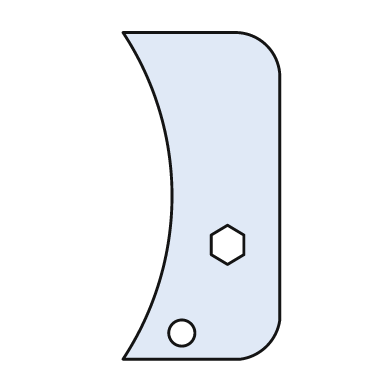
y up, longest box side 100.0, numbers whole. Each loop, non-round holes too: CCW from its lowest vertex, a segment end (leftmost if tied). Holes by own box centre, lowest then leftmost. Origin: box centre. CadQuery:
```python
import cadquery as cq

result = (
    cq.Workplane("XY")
    .moveTo(-24.0, -50.0)
    .lineTo(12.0, -50.0)
    .threePointArc((20.0, -46.0), (24.0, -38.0))
    .lineTo(24.0, 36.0)
    .threePointArc((20.0, 46.0), (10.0, 50.0))
    .lineTo(-24.0, 50.0)
    .threePointArc((-9.0, 0.0), (-24.0, -50.0))
    .close()
    .moveTo(-6.0, -42.0)
    .circle(4.0)
    .moveTo(8.0, -21.0)
    .lineTo(13.0, -18.0)
    .lineTo(13.0, -12.0)
    .lineTo(8.0, -9.0)
    .lineTo(3.0, -12.0)
    .lineTo(3.0, -18.0)
    .close()
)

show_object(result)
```